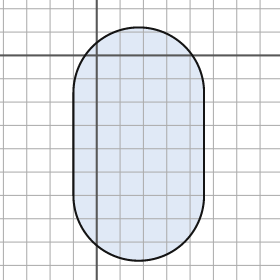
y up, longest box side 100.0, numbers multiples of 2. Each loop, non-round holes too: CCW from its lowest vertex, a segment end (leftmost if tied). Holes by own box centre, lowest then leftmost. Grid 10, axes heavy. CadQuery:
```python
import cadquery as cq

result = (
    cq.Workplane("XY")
    .moveTo(-10.0, -60.0)
    .threePointArc((18.0, -88.0), (46.0, -60.0))
    .lineTo(46.0, -16.0)
    .threePointArc((18.0, 12.0), (-10.0, -16.0))
    .close()
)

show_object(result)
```